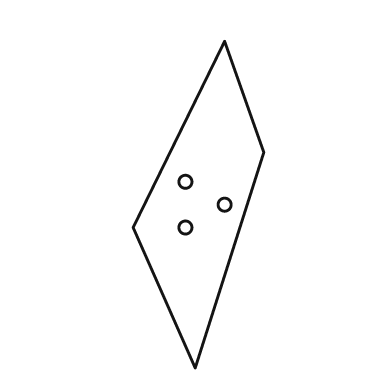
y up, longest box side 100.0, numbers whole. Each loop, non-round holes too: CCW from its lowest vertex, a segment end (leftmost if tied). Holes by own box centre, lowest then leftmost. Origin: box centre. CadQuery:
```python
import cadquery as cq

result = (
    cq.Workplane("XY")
    .moveTo(-1.0, -50.0)
    .lineTo(20.0, 16.0)
    .lineTo(8.0, 50.0)
    .lineTo(-20.0, -7.0)
    .close()
    .moveTo(-4.0, -7.0)
    .circle(2.0)
    .moveTo(8.0, 0.0)
    .circle(2.0)
    .moveTo(-4.0, 7.0)
    .circle(2.0)
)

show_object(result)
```